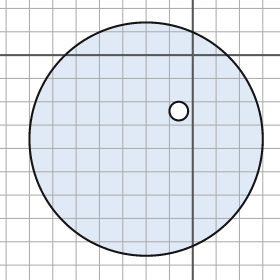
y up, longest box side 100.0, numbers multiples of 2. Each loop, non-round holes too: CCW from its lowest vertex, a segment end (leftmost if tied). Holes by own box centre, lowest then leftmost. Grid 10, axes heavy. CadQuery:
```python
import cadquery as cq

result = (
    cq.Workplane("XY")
    .moveTo(-20.0, -36.0)
    .circle(50.0)
    .moveTo(-6.0, -24.0)
    .circle(4.0)
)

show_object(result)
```